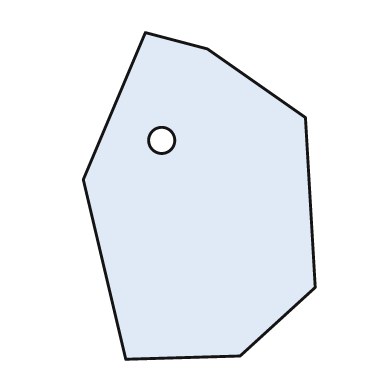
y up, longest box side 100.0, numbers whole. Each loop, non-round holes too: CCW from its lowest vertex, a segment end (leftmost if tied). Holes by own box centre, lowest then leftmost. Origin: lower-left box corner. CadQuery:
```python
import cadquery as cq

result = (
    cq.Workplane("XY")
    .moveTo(13.0, 0.0)
    .lineTo(48.0, 1.0)
    .lineTo(71.0, 22.0)
    .lineTo(68.0, 74.0)
    .lineTo(38.0, 95.0)
    .lineTo(19.0, 100.0)
    .lineTo(0.0, 55.0)
    .close()
    .moveTo(24.0, 67.0)
    .circle(4.0)
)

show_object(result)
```